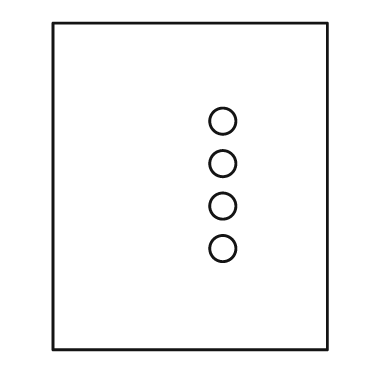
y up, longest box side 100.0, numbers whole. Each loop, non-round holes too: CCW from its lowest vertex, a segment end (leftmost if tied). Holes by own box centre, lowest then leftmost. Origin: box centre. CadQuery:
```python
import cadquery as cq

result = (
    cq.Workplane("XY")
    .moveTo(-42.0, -50.0)
    .lineTo(42.0, -50.0)
    .lineTo(42.0, 50.0)
    .lineTo(-42.0, 50.0)
    .close()
    .moveTo(10.0, -19.0)
    .circle(4.0)
    .moveTo(10.0, -6.0)
    .circle(4.0)
    .moveTo(10.0, 7.0)
    .circle(4.0)
    .moveTo(10.0, 20.0)
    .circle(4.0)
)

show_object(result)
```